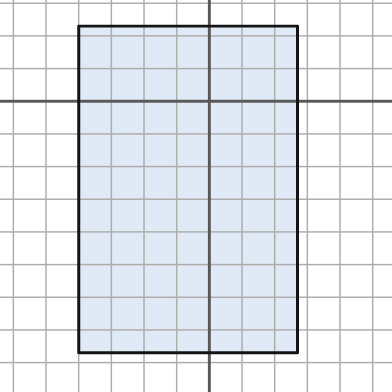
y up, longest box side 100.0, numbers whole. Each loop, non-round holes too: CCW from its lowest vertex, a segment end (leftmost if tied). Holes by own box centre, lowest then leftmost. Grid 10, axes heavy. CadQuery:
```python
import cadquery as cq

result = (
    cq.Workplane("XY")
    .moveTo(-40.0, -77.0)
    .lineTo(27.0, -77.0)
    .lineTo(27.0, 23.0)
    .lineTo(-40.0, 23.0)
    .close()
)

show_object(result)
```